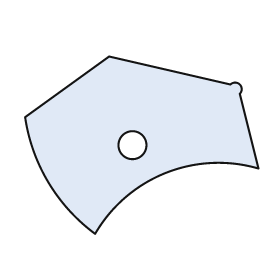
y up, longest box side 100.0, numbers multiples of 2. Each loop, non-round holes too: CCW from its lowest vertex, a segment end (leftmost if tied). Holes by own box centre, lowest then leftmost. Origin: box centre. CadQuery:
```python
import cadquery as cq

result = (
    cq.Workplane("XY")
    .moveTo(-20.0, -38.0)
    .threePointArc((10.0, -12.0), (50.0, -10.0))
    .lineTo(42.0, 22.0)
    .threePointArc((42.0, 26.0), (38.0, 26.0))
    .lineTo(-14.0, 38.0)
    .lineTo(-50.0, 12.0)
    .threePointArc((-40.0, -16.0), (-20.0, -38.0))
    .close()
    .moveTo(-4.0, 0.0)
    .circle(6.0)
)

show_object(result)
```